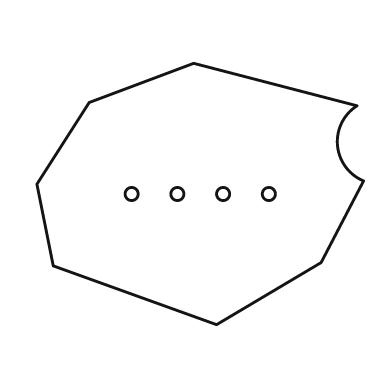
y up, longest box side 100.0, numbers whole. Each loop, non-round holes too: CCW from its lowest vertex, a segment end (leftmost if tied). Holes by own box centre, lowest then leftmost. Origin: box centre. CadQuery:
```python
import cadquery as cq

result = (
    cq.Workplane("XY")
    .moveTo(5.0, -40.0)
    .lineTo(37.0, -21.0)
    .lineTo(50.0, 4.0)
    .threePointArc((42.0, 15.0), (48.0, 27.0))
    .lineTo(-2.0, 40.0)
    .lineTo(-34.0, 28.0)
    .lineTo(-50.0, 3.0)
    .lineTo(-45.0, -22.0)
    .close()
    .moveTo(-21.0, 0.0)
    .circle(2.0)
    .moveTo(-7.0, 0.0)
    .circle(2.0)
    .moveTo(7.0, 0.0)
    .circle(2.0)
    .moveTo(21.0, 0.0)
    .circle(2.0)
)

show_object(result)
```